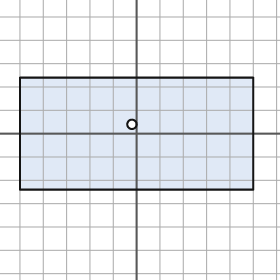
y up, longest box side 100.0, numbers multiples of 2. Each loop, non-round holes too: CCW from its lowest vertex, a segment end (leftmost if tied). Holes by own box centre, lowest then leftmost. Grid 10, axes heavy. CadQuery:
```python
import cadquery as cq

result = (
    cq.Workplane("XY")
    .moveTo(-50.0, -24.0)
    .lineTo(50.0, -24.0)
    .lineTo(50.0, 24.0)
    .lineTo(-50.0, 24.0)
    .close()
    .moveTo(-2.0, 4.0)
    .circle(2.0)
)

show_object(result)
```